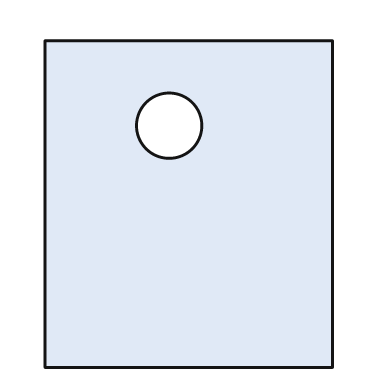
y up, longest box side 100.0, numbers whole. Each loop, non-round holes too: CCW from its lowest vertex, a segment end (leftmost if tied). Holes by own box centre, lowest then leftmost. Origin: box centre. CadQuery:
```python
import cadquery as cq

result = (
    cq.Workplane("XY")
    .moveTo(-44.0, -50.0)
    .lineTo(44.0, -50.0)
    .lineTo(44.0, 50.0)
    .lineTo(-44.0, 50.0)
    .close()
    .moveTo(-6.0, 24.0)
    .circle(10.0)
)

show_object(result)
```